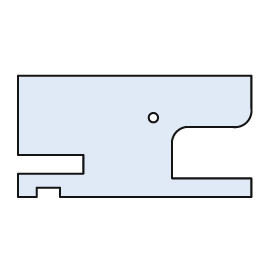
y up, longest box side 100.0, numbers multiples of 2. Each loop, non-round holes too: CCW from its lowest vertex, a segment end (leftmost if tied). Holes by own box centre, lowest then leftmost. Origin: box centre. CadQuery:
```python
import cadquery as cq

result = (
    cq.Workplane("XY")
    .moveTo(-50.0, -26.0)
    .lineTo(-42.0, -26.0)
    .lineTo(-42.0, -22.0)
    .lineTo(-32.0, -22.0)
    .lineTo(-32.0, -26.0)
    .lineTo(50.0, -26.0)
    .lineTo(50.0, -18.0)
    .lineTo(16.0, -18.0)
    .lineTo(16.0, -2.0)
    .threePointArc((18.0, 2.0), (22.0, 4.0))
    .lineTo(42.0, 4.0)
    .threePointArc((48.0, 6.0), (50.0, 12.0))
    .lineTo(50.0, 26.0)
    .lineTo(-50.0, 26.0)
    .lineTo(-50.0, -8.0)
    .lineTo(-22.0, -8.0)
    .lineTo(-22.0, -16.0)
    .lineTo(-50.0, -16.0)
    .close()
    .moveTo(8.0, 8.0)
    .circle(2.0)
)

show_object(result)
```